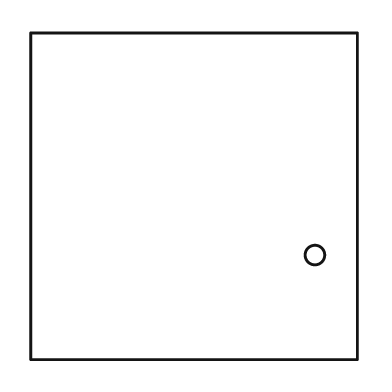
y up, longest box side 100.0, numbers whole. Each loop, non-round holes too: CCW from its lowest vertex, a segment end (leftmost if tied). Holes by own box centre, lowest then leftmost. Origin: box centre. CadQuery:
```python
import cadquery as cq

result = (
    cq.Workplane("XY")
    .moveTo(-50.0, -50.0)
    .lineTo(50.0, -50.0)
    .lineTo(50.0, 50.0)
    .lineTo(-50.0, 50.0)
    .close()
    .moveTo(37.0, -18.0)
    .circle(3.0)
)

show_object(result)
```